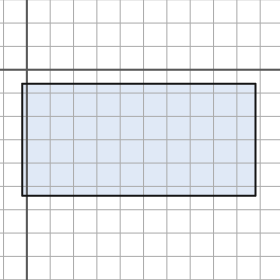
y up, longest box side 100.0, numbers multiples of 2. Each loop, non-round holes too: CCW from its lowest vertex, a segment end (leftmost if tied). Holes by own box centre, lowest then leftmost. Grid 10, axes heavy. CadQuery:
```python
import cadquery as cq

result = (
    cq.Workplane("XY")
    .moveTo(-2.0, -54.0)
    .lineTo(98.0, -54.0)
    .lineTo(98.0, -6.0)
    .lineTo(-2.0, -6.0)
    .close()
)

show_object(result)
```